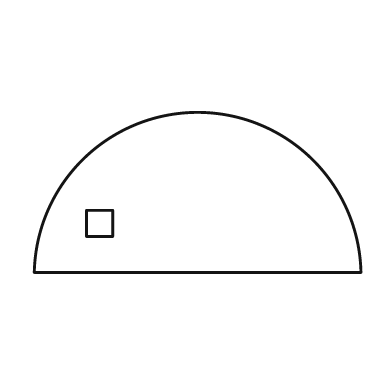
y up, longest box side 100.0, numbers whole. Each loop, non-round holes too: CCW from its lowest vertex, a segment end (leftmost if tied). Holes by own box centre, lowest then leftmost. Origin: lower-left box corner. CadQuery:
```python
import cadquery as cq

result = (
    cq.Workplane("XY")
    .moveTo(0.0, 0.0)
    .lineTo(100.0, 0.0)
    .threePointArc((50.0, 49.0), (0.0, 0.0))
    .close()
    .moveTo(16.0, 11.0)
    .lineTo(24.0, 11.0)
    .lineTo(24.0, 19.0)
    .lineTo(16.0, 19.0)
    .close()
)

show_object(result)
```